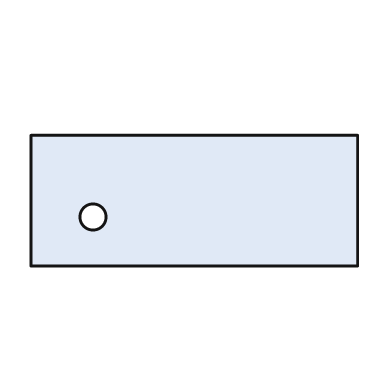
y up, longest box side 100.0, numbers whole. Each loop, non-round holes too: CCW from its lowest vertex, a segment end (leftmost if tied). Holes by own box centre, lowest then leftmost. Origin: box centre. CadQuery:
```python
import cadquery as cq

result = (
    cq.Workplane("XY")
    .moveTo(-50.0, -20.0)
    .lineTo(50.0, -20.0)
    .lineTo(50.0, 20.0)
    .lineTo(-50.0, 20.0)
    .close()
    .moveTo(-31.0, -5.0)
    .circle(4.0)
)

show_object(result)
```